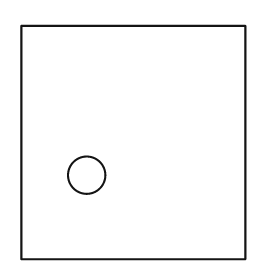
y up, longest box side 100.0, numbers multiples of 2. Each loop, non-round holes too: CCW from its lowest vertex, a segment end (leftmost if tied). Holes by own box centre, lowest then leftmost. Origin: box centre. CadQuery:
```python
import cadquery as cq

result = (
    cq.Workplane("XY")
    .moveTo(-48.0, -50.0)
    .lineTo(48.0, -50.0)
    .lineTo(48.0, 50.0)
    .lineTo(-48.0, 50.0)
    .close()
    .moveTo(-20.0, -14.0)
    .circle(8.0)
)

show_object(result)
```